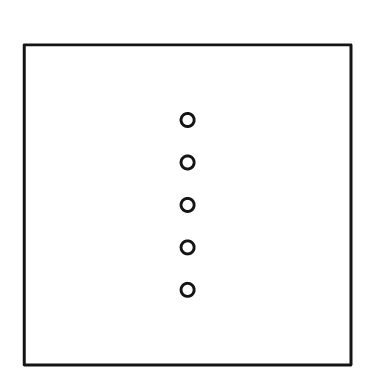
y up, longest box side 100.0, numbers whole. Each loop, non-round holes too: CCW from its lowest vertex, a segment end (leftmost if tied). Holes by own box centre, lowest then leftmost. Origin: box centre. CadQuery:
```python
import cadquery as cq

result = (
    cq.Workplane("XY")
    .moveTo(-50.0, -49.0)
    .lineTo(50.0, -49.0)
    .lineTo(50.0, 49.0)
    .lineTo(-50.0, 49.0)
    .close()
    .moveTo(0.0, -26.0)
    .circle(2.0)
    .moveTo(0.0, -13.0)
    .circle(2.0)
    .moveTo(0.0, 0.0)
    .circle(2.0)
    .moveTo(0.0, 13.0)
    .circle(2.0)
    .moveTo(0.0, 26.0)
    .circle(2.0)
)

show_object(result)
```